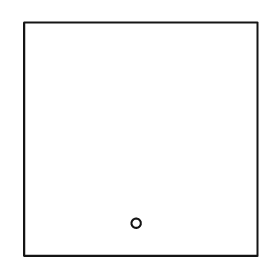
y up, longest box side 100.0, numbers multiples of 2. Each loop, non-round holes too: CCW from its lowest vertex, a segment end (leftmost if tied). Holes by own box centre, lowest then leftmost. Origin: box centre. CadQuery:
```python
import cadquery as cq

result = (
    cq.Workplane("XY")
    .moveTo(-50.0, -50.0)
    .lineTo(50.0, -50.0)
    .lineTo(50.0, 50.0)
    .lineTo(-50.0, 50.0)
    .close()
    .moveTo(-2.0, -36.0)
    .circle(2.0)
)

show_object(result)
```